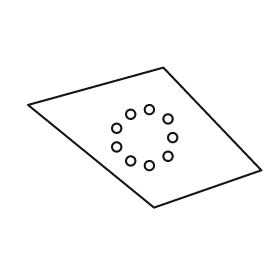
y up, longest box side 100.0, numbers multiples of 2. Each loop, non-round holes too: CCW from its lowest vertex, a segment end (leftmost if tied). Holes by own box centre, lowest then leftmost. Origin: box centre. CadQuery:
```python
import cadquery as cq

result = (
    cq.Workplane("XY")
    .moveTo(4.0, -30.0)
    .lineTo(50.0, -14.0)
    .lineTo(8.0, 30.0)
    .lineTo(-50.0, 14.0)
    .close()
    .moveTo(2.0, -12.0)
    .circle(2.0)
    .moveTo(-6.0, -10.0)
    .circle(2.0)
    .moveTo(10.0, -8.0)
    .circle(2.0)
    .moveTo(-12.0, -4.0)
    .circle(2.0)
    .moveTo(12.0, 0.0)
    .circle(2.0)
    .moveTo(-12.0, 4.0)
    .circle(2.0)
    .moveTo(10.0, 8.0)
    .circle(2.0)
    .moveTo(-6.0, 10.0)
    .circle(2.0)
    .moveTo(2.0, 12.0)
    .circle(2.0)
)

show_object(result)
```